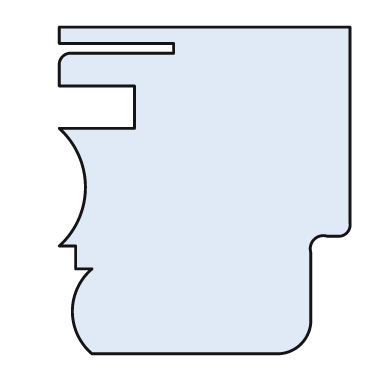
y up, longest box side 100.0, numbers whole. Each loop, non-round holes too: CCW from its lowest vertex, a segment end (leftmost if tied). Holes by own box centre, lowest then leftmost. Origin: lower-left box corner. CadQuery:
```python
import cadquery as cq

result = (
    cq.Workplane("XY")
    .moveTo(10.0, 0.0)
    .lineTo(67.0, 0.0)
    .threePointArc((74.0, 3.0), (77.0, 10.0))
    .lineTo(77.0, 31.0)
    .threePointArc((78.0, 35.0), (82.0, 36.0))
    .lineTo(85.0, 36.0)
    .threePointArc((88.0, 37.0), (89.0, 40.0))
    .lineTo(89.0, 100.0)
    .lineTo(0.0, 100.0)
    .lineTo(0.0, 95.0)
    .lineTo(35.0, 95.0)
    .lineTo(35.0, 92.0)
    .lineTo(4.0, 92.0)
    .threePointArc((1.0, 91.0), (0.0, 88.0))
    .lineTo(0.0, 82.0)
    .lineTo(23.0, 82.0)
    .lineTo(23.0, 69.0)
    .lineTo(0.0, 69.0)
    .threePointArc((8.0, 51.0), (0.0, 33.0))
    .lineTo(5.0, 33.0)
    .lineTo(5.0, 26.0)
    .lineTo(10.0, 26.0)
    .threePointArc((4.0, 13.0), (10.0, 0.0))
    .close()
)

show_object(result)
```